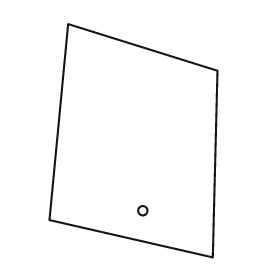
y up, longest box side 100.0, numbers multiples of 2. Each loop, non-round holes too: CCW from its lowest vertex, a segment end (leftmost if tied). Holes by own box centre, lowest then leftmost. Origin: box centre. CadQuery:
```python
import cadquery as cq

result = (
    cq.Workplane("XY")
    .moveTo(34.0, -50.0)
    .lineTo(36.0, 30.0)
    .lineTo(-28.0, 50.0)
    .lineTo(-36.0, -34.0)
    .close()
    .moveTo(4.0, -30.0)
    .circle(2.0)
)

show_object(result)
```